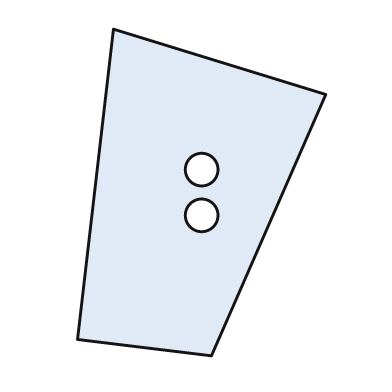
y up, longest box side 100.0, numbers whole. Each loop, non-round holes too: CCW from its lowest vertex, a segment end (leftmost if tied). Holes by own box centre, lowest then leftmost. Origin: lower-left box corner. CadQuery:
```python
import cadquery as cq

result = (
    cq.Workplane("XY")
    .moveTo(41.0, 0.0)
    .lineTo(76.0, 80.0)
    .lineTo(11.0, 100.0)
    .lineTo(0.0, 5.0)
    .close()
    .moveTo(38.0, 43.0)
    .circle(5.0)
    .moveTo(38.0, 57.0)
    .circle(5.0)
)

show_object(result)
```